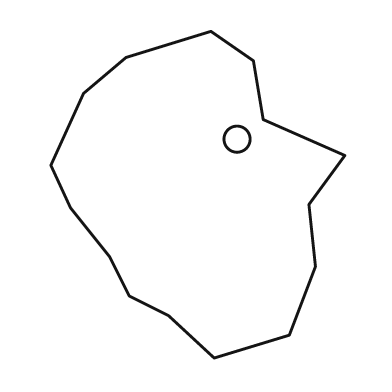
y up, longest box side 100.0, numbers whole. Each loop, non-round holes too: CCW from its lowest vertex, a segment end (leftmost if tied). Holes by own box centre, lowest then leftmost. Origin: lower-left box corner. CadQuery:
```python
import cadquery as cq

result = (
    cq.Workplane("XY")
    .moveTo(50.0, 0.0)
    .lineTo(73.0, 7.0)
    .lineTo(81.0, 28.0)
    .lineTo(79.0, 47.0)
    .lineTo(90.0, 62.0)
    .lineTo(65.0, 73.0)
    .lineTo(62.0, 91.0)
    .lineTo(49.0, 100.0)
    .lineTo(23.0, 92.0)
    .lineTo(10.0, 81.0)
    .lineTo(0.0, 59.0)
    .lineTo(6.0, 46.0)
    .lineTo(18.0, 31.0)
    .lineTo(24.0, 19.0)
    .lineTo(36.0, 13.0)
    .close()
    .moveTo(57.0, 67.0)
    .circle(4.0)
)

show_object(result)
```